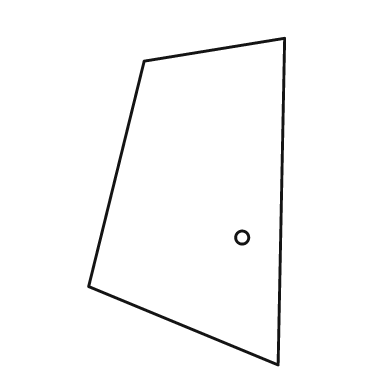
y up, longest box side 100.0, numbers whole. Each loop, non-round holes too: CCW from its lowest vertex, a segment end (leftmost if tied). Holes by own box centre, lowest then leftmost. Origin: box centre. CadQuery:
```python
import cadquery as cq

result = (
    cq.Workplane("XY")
    .moveTo(28.0, -50.0)
    .lineTo(30.0, 50.0)
    .lineTo(-13.0, 43.0)
    .lineTo(-30.0, -26.0)
    .close()
    .moveTo(17.0, -11.0)
    .circle(2.0)
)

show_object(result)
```